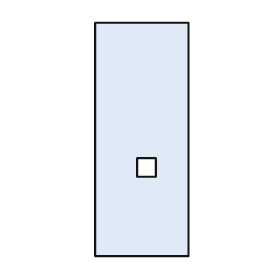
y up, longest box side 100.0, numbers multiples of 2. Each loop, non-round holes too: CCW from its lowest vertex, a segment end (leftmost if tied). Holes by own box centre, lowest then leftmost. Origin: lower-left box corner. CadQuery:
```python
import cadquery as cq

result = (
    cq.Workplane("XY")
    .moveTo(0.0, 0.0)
    .lineTo(40.0, 0.0)
    .lineTo(40.0, 100.0)
    .lineTo(0.0, 100.0)
    .close()
    .moveTo(18.0, 34.0)
    .lineTo(26.0, 34.0)
    .lineTo(26.0, 42.0)
    .lineTo(18.0, 42.0)
    .close()
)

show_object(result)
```